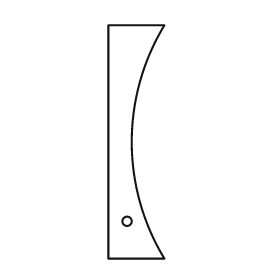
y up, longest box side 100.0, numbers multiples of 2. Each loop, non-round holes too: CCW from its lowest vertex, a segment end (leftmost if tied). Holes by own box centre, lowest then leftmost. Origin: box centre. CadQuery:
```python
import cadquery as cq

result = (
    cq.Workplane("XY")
    .moveTo(-12.0, -50.0)
    .lineTo(12.0, -50.0)
    .threePointArc((-2.0, 0.0), (12.0, 50.0))
    .lineTo(-12.0, 50.0)
    .close()
    .moveTo(-4.0, -34.0)
    .circle(2.0)
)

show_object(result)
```